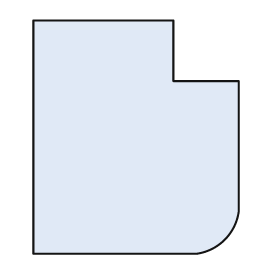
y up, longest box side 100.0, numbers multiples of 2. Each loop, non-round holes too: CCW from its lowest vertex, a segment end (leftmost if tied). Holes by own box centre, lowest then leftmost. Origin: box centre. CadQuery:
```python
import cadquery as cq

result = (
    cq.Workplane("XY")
    .moveTo(-44.0, -50.0)
    .lineTo(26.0, -50.0)
    .threePointArc((38.0, -44.0), (44.0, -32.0))
    .lineTo(44.0, 24.0)
    .lineTo(16.0, 24.0)
    .lineTo(16.0, 50.0)
    .lineTo(-44.0, 50.0)
    .close()
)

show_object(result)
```